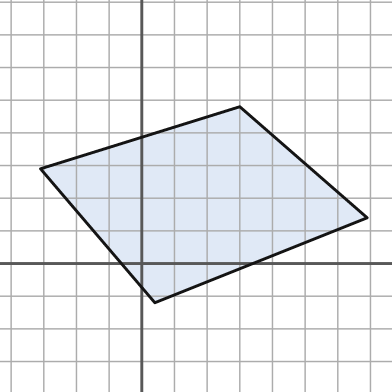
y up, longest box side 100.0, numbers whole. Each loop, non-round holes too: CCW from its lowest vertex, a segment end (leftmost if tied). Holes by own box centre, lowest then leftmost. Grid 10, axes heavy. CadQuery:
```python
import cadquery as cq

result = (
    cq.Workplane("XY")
    .moveTo(4.0, -12.0)
    .lineTo(69.0, 14.0)
    .lineTo(30.0, 48.0)
    .lineTo(-31.0, 29.0)
    .close()
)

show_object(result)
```